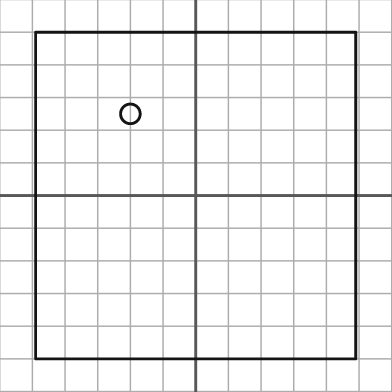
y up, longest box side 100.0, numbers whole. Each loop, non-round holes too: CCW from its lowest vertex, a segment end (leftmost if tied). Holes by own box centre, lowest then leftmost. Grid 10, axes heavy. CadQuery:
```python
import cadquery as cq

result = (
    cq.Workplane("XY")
    .moveTo(-49.0, -50.0)
    .lineTo(49.0, -50.0)
    .lineTo(49.0, 50.0)
    .lineTo(-49.0, 50.0)
    .close()
    .moveTo(-20.0, 25.0)
    .circle(3.0)
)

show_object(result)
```